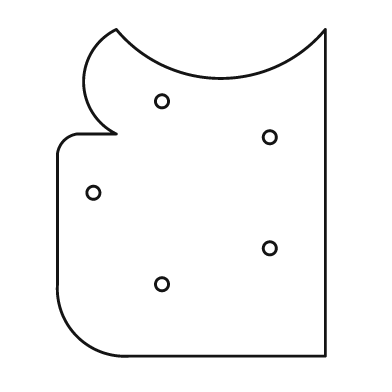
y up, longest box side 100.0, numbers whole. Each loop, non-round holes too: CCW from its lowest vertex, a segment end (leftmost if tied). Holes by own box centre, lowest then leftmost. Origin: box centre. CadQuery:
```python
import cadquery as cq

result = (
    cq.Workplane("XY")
    .moveTo(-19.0, -50.0)
    .lineTo(41.0, -50.0)
    .lineTo(41.0, 50.0)
    .threePointArc((9.0, 35.0), (-23.0, 50.0))
    .threePointArc((-33.0, 34.0), (-23.0, 18.0))
    .lineTo(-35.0, 18.0)
    .threePointArc((-39.0, 16.0), (-41.0, 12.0))
    .lineTo(-41.0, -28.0)
    .threePointArc((-35.0, -44.0), (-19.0, -50.0))
    .close()
    .moveTo(-9.0, -28.0)
    .circle(2.0)
    .moveTo(24.0, -17.0)
    .circle(2.0)
    .moveTo(-30.0, 0.0)
    .circle(2.0)
    .moveTo(24.0, 17.0)
    .circle(2.0)
    .moveTo(-9.0, 28.0)
    .circle(2.0)
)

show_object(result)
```